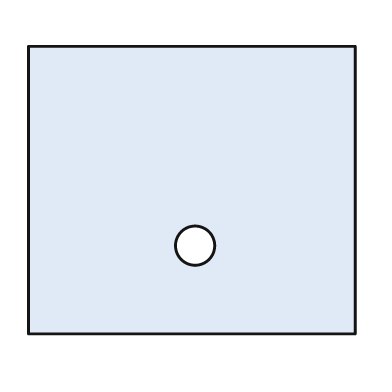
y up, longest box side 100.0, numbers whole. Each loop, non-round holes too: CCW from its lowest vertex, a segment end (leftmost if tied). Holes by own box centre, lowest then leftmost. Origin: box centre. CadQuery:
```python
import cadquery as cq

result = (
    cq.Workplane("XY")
    .moveTo(-50.0, -44.0)
    .lineTo(50.0, -44.0)
    .lineTo(50.0, 44.0)
    .lineTo(-50.0, 44.0)
    .close()
    .moveTo(1.0, -17.0)
    .circle(6.0)
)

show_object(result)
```